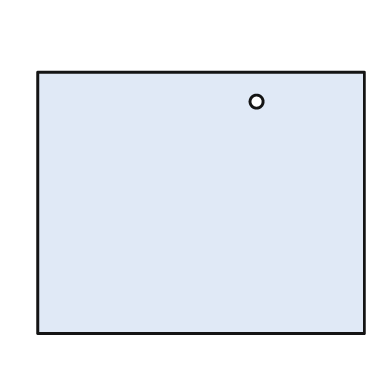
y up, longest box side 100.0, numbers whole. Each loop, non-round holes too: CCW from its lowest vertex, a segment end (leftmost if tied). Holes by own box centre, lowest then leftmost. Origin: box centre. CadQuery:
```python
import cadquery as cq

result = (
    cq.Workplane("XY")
    .moveTo(-50.0, -40.0)
    .lineTo(50.0, -40.0)
    .lineTo(50.0, 40.0)
    .lineTo(-50.0, 40.0)
    .close()
    .moveTo(17.0, 31.0)
    .circle(2.0)
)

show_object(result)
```